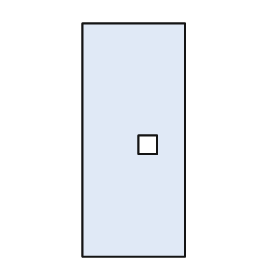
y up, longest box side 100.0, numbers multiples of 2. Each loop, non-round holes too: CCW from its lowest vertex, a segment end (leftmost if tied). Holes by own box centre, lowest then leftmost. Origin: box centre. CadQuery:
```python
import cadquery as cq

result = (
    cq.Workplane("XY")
    .moveTo(-22.0, -50.0)
    .lineTo(22.0, -50.0)
    .lineTo(22.0, 50.0)
    .lineTo(-22.0, 50.0)
    .close()
    .moveTo(2.0, -6.0)
    .lineTo(10.0, -6.0)
    .lineTo(10.0, 2.0)
    .lineTo(2.0, 2.0)
    .close()
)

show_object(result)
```